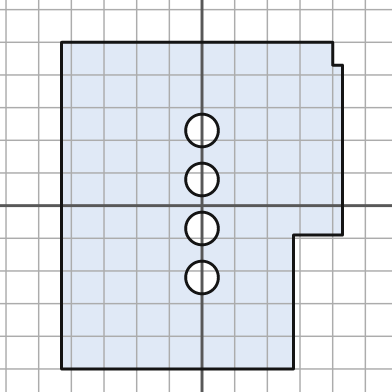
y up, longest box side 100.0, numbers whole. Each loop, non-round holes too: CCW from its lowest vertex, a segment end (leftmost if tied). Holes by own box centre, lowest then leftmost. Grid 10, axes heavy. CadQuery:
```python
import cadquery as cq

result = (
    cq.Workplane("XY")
    .moveTo(-43.0, -50.0)
    .lineTo(28.0, -50.0)
    .lineTo(28.0, -9.0)
    .lineTo(43.0, -9.0)
    .lineTo(43.0, 43.0)
    .lineTo(40.0, 43.0)
    .lineTo(40.0, 50.0)
    .lineTo(-43.0, 50.0)
    .close()
    .moveTo(0.0, -22.0)
    .circle(5.0)
    .moveTo(0.0, -7.0)
    .circle(5.0)
    .moveTo(0.0, 8.0)
    .circle(5.0)
    .moveTo(0.0, 23.0)
    .circle(5.0)
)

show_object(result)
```